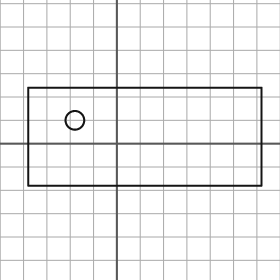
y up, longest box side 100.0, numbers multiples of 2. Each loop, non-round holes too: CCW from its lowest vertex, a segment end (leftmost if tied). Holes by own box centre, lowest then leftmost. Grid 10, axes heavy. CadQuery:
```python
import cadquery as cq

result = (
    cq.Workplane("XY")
    .moveTo(-38.0, -18.0)
    .lineTo(62.0, -18.0)
    .lineTo(62.0, 24.0)
    .lineTo(-38.0, 24.0)
    .close()
    .moveTo(-18.0, 10.0)
    .circle(4.0)
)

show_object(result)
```